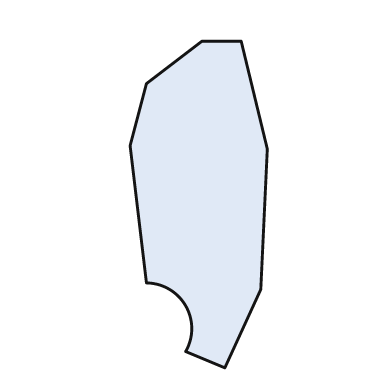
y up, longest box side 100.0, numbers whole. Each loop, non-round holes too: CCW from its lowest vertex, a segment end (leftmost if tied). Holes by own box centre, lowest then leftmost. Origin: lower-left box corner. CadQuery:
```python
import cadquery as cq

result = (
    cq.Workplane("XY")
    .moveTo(29.0, 0.0)
    .lineTo(40.0, 24.0)
    .lineTo(42.0, 67.0)
    .lineTo(34.0, 100.0)
    .lineTo(22.0, 100.0)
    .lineTo(5.0, 87.0)
    .lineTo(0.0, 68.0)
    .lineTo(5.0, 26.0)
    .threePointArc((17.0, 19.0), (17.0, 5.0))
    .close()
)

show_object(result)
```